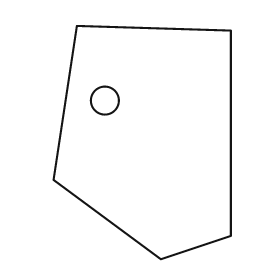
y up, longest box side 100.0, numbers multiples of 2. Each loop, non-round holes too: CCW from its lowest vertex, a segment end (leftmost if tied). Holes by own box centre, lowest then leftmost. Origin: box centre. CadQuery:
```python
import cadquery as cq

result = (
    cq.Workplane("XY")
    .moveTo(8.0, -50.0)
    .lineTo(38.0, -40.0)
    .lineTo(38.0, 48.0)
    .lineTo(-28.0, 50.0)
    .lineTo(-38.0, -16.0)
    .close()
    .moveTo(-16.0, 18.0)
    .circle(6.0)
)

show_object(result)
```